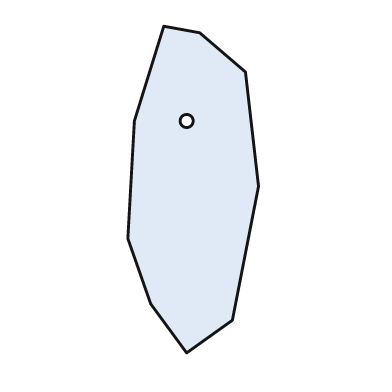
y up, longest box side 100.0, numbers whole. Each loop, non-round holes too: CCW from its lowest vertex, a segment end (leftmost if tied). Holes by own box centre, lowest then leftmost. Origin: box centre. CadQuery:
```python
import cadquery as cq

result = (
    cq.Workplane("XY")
    .moveTo(-2.0, -50.0)
    .lineTo(12.0, -40.0)
    .lineTo(20.0, 1.0)
    .lineTo(16.0, 36.0)
    .lineTo(2.0, 48.0)
    .lineTo(-9.0, 50.0)
    .lineTo(-18.0, 21.0)
    .lineTo(-20.0, -15.0)
    .lineTo(-13.0, -35.0)
    .close()
    .moveTo(-2.0, 21.0)
    .circle(2.0)
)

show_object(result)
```